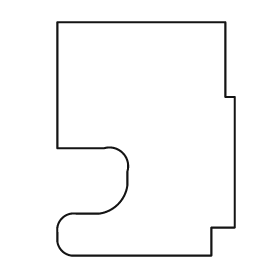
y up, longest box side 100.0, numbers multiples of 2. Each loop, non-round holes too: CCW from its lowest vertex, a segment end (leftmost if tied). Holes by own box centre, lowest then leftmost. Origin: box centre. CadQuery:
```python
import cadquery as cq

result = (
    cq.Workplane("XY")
    .moveTo(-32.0, -50.0)
    .lineTo(28.0, -50.0)
    .lineTo(28.0, -38.0)
    .lineTo(38.0, -38.0)
    .lineTo(38.0, 18.0)
    .lineTo(34.0, 18.0)
    .lineTo(34.0, 50.0)
    .lineTo(-38.0, 50.0)
    .lineTo(-38.0, -4.0)
    .lineTo(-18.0, -4.0)
    .threePointArc((-10.0, -6.0), (-8.0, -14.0))
    .lineTo(-8.0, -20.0)
    .threePointArc((-12.0, -28.0), (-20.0, -32.0))
    .lineTo(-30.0, -32.0)
    .threePointArc((-36.0, -34.0), (-38.0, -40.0))
    .lineTo(-38.0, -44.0)
    .threePointArc((-36.0, -48.0), (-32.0, -50.0))
    .close()
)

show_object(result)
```